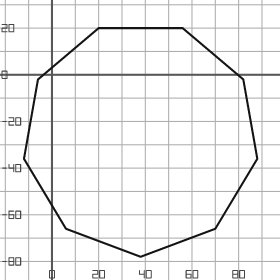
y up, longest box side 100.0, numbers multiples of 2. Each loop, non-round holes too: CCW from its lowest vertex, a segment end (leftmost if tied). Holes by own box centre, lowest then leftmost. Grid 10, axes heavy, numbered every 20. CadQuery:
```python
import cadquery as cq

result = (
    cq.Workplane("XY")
    .moveTo(38.0, -78.0)
    .lineTo(70.0, -66.0)
    .lineTo(88.0, -36.0)
    .lineTo(82.0, -2.0)
    .lineTo(56.0, 20.0)
    .lineTo(20.0, 20.0)
    .lineTo(-6.0, -2.0)
    .lineTo(-12.0, -36.0)
    .lineTo(6.0, -66.0)
    .close()
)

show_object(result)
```